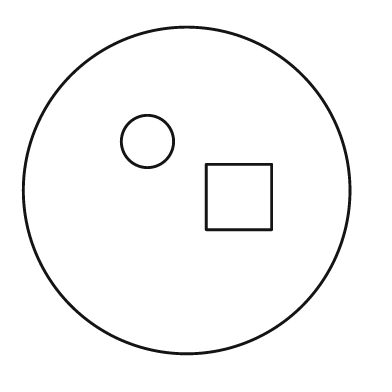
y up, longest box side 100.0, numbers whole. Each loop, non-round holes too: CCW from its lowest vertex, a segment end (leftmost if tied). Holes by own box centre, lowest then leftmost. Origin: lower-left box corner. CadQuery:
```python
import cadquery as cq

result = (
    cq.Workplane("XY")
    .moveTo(50.0, 50.0)
    .circle(50.0)
    .moveTo(56.0, 38.0)
    .lineTo(76.0, 38.0)
    .lineTo(76.0, 58.0)
    .lineTo(56.0, 58.0)
    .close()
    .moveTo(38.0, 65.0)
    .circle(8.0)
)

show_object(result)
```